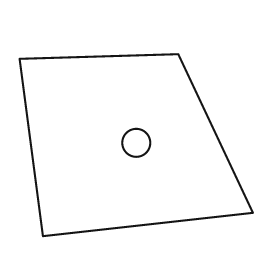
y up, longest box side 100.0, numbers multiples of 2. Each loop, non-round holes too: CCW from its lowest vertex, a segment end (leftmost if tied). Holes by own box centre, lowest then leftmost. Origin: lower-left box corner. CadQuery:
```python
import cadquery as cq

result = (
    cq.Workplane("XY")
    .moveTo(10.0, 0.0)
    .lineTo(100.0, 10.0)
    .lineTo(68.0, 78.0)
    .lineTo(0.0, 76.0)
    .close()
    .moveTo(50.0, 40.0)
    .circle(6.0)
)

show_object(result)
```